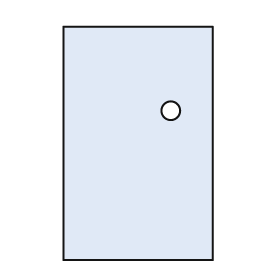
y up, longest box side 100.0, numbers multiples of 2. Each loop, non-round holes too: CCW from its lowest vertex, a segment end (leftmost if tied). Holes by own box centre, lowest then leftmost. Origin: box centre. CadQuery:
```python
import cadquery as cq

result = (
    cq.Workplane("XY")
    .moveTo(-32.0, -50.0)
    .lineTo(32.0, -50.0)
    .lineTo(32.0, 50.0)
    .lineTo(-32.0, 50.0)
    .close()
    .moveTo(14.0, 14.0)
    .circle(4.0)
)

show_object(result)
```